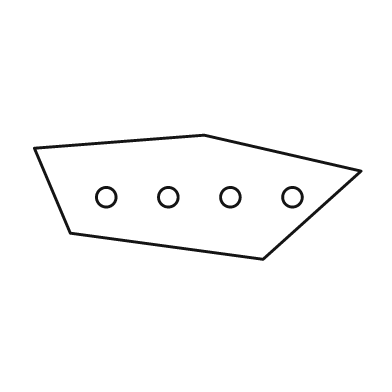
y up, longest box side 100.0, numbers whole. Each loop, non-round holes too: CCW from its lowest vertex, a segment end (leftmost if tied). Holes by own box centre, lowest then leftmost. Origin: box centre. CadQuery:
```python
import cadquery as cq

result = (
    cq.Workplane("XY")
    .moveTo(20.0, -19.0)
    .lineTo(50.0, 8.0)
    .lineTo(2.0, 19.0)
    .lineTo(-50.0, 15.0)
    .lineTo(-39.0, -11.0)
    .close()
    .moveTo(-28.0, 0.0)
    .circle(3.0)
    .moveTo(-9.0, 0.0)
    .circle(3.0)
    .moveTo(10.0, 0.0)
    .circle(3.0)
    .moveTo(29.0, 0.0)
    .circle(3.0)
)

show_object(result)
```